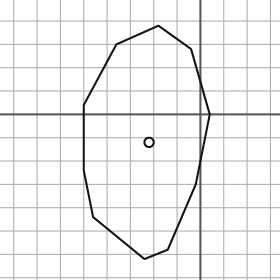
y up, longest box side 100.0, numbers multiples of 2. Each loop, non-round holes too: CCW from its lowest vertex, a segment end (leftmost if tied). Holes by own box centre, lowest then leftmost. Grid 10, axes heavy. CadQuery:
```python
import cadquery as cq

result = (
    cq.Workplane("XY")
    .moveTo(-24.0, -62.0)
    .lineTo(-14.0, -58.0)
    .lineTo(-2.0, -30.0)
    .lineTo(4.0, 0.0)
    .lineTo(-4.0, 28.0)
    .lineTo(-18.0, 38.0)
    .lineTo(-36.0, 30.0)
    .lineTo(-50.0, 4.0)
    .lineTo(-50.0, -24.0)
    .lineTo(-46.0, -44.0)
    .close()
    .moveTo(-22.0, -12.0)
    .circle(2.0)
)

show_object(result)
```